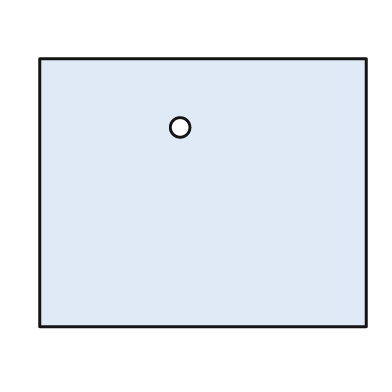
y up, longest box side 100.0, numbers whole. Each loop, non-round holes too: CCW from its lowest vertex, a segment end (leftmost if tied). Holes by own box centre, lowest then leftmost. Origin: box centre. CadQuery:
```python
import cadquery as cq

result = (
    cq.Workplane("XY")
    .moveTo(-50.0, -41.0)
    .lineTo(50.0, -41.0)
    .lineTo(50.0, 41.0)
    .lineTo(-50.0, 41.0)
    .close()
    .moveTo(-7.0, 20.0)
    .circle(3.0)
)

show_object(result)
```